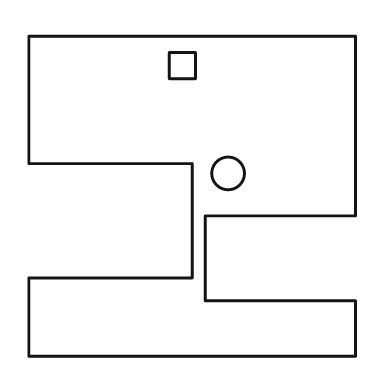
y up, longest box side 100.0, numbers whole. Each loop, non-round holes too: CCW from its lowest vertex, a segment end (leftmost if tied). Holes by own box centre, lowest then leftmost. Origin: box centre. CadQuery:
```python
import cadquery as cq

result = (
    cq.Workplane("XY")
    .moveTo(-50.0, -49.0)
    .lineTo(50.0, -49.0)
    .lineTo(50.0, -32.0)
    .lineTo(4.0, -32.0)
    .lineTo(4.0, -6.0)
    .lineTo(50.0, -6.0)
    .lineTo(50.0, 49.0)
    .lineTo(-50.0, 49.0)
    .lineTo(-50.0, 10.0)
    .lineTo(0.0, 10.0)
    .lineTo(0.0, -25.0)
    .lineTo(-50.0, -25.0)
    .close()
    .moveTo(11.0, 7.0)
    .circle(5.0)
    .moveTo(-7.0, 36.0)
    .lineTo(1.0, 36.0)
    .lineTo(1.0, 44.0)
    .lineTo(-7.0, 44.0)
    .close()
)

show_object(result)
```